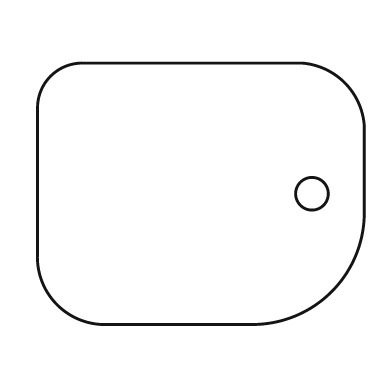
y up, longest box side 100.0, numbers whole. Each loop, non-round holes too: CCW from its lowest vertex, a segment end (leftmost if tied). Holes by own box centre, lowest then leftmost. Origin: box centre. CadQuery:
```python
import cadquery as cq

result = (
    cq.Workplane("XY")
    .moveTo(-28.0, -40.0)
    .lineTo(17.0, -40.0)
    .threePointArc((40.0, -30.0), (50.0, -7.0))
    .lineTo(50.0, 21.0)
    .threePointArc((44.0, 34.0), (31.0, 40.0))
    .lineTo(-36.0, 40.0)
    .threePointArc((-46.0, 36.0), (-50.0, 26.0))
    .lineTo(-50.0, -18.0)
    .threePointArc((-44.0, -34.0), (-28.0, -40.0))
    .close()
    .moveTo(34.0, 0.0)
    .circle(5.0)
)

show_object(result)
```